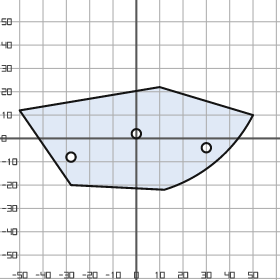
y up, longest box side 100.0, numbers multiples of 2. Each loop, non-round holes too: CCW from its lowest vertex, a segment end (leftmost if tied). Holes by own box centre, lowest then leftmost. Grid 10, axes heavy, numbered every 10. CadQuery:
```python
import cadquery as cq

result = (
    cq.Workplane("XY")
    .moveTo(12.0, -22.0)
    .threePointArc((34.0, -10.0), (50.0, 10.0))
    .lineTo(10.0, 22.0)
    .lineTo(-50.0, 12.0)
    .lineTo(-28.0, -20.0)
    .close()
    .moveTo(-28.0, -8.0)
    .circle(2.0)
    .moveTo(30.0, -4.0)
    .circle(2.0)
    .moveTo(0.0, 2.0)
    .circle(2.0)
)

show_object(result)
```